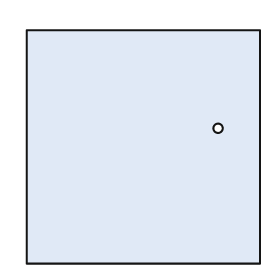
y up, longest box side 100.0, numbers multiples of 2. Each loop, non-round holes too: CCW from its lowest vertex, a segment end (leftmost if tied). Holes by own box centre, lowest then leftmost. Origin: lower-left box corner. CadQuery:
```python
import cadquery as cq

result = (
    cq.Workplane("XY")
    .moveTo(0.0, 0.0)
    .lineTo(100.0, 0.0)
    .lineTo(100.0, 100.0)
    .lineTo(0.0, 100.0)
    .close()
    .moveTo(82.0, 58.0)
    .circle(2.0)
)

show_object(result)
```